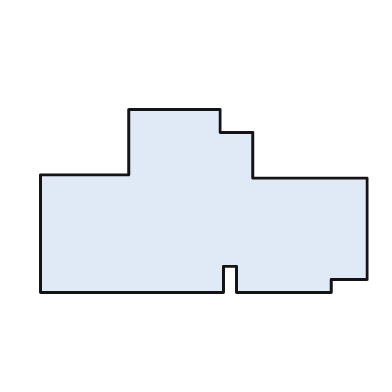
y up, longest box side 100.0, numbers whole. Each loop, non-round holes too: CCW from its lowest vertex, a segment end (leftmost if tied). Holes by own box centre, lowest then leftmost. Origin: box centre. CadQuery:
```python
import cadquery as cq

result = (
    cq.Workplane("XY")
    .moveTo(-50.0, -28.0)
    .lineTo(6.0, -28.0)
    .lineTo(6.0, -20.0)
    .lineTo(10.0, -20.0)
    .lineTo(10.0, -28.0)
    .lineTo(39.0, -28.0)
    .lineTo(39.0, -24.0)
    .lineTo(50.0, -24.0)
    .lineTo(50.0, 7.0)
    .lineTo(15.0, 7.0)
    .lineTo(15.0, 21.0)
    .lineTo(5.0, 21.0)
    .lineTo(5.0, 28.0)
    .lineTo(-23.0, 28.0)
    .lineTo(-23.0, 8.0)
    .lineTo(-50.0, 8.0)
    .close()
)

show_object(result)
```